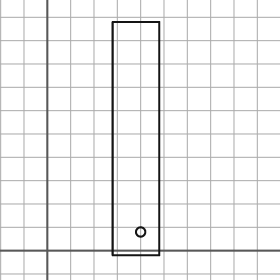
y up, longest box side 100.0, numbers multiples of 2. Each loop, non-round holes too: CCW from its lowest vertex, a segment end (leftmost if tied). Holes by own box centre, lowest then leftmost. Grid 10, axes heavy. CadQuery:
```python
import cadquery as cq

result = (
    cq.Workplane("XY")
    .moveTo(28.0, -2.0)
    .lineTo(48.0, -2.0)
    .lineTo(48.0, 98.0)
    .lineTo(28.0, 98.0)
    .close()
    .moveTo(40.0, 8.0)
    .circle(2.0)
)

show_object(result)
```